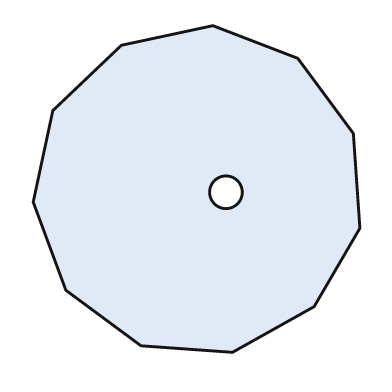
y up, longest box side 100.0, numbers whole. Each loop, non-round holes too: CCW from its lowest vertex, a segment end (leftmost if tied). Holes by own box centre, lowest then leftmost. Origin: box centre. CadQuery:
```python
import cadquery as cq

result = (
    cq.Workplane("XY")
    .moveTo(11.0, -50.0)
    .lineTo(36.0, -36.0)
    .lineTo(50.0, -12.0)
    .lineTo(48.0, 17.0)
    .lineTo(31.0, 40.0)
    .lineTo(5.0, 50.0)
    .lineTo(-23.0, 44.0)
    .lineTo(-44.0, 24.0)
    .lineTo(-50.0, -4.0)
    .lineTo(-40.0, -31.0)
    .lineTo(-17.0, -48.0)
    .close()
    .moveTo(9.0, -1.0)
    .circle(5.0)
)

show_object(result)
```